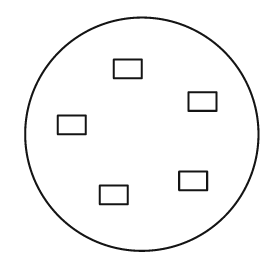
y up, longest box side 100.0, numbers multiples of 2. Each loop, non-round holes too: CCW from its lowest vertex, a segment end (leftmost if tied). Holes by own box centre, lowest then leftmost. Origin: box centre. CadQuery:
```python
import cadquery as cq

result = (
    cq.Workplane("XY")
    .moveTo(0.0, 0.0)
    .circle(50.0)
    .moveTo(-18.0, -30.0)
    .lineTo(-6.0, -30.0)
    .lineTo(-6.0, -22.0)
    .lineTo(-18.0, -22.0)
    .close()
    .moveTo(16.0, -24.0)
    .lineTo(28.0, -24.0)
    .lineTo(28.0, -16.0)
    .lineTo(16.0, -16.0)
    .close()
    .moveTo(-36.0, 0.0)
    .lineTo(-24.0, 0.0)
    .lineTo(-24.0, 8.0)
    .lineTo(-36.0, 8.0)
    .close()
    .moveTo(20.0, 10.0)
    .lineTo(32.0, 10.0)
    .lineTo(32.0, 18.0)
    .lineTo(20.0, 18.0)
    .close()
    .moveTo(-12.0, 24.0)
    .lineTo(0.0, 24.0)
    .lineTo(0.0, 32.0)
    .lineTo(-12.0, 32.0)
    .close()
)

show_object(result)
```